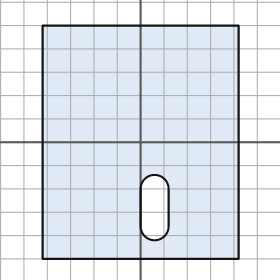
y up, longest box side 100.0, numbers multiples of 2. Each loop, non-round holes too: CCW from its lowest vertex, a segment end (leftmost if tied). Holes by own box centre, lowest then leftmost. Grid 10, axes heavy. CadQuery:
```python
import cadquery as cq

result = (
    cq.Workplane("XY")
    .moveTo(-42.0, -50.0)
    .lineTo(42.0, -50.0)
    .lineTo(42.0, 50.0)
    .lineTo(-42.0, 50.0)
    .close()
    .moveTo(0.0, -36.0)
    .threePointArc((6.0, -42.0), (12.0, -36.0))
    .lineTo(12.0, -20.0)
    .threePointArc((6.0, -14.0), (0.0, -20.0))
    .close()
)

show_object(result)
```